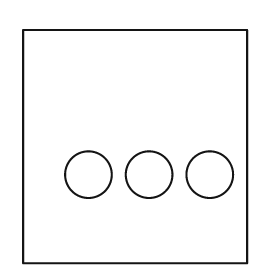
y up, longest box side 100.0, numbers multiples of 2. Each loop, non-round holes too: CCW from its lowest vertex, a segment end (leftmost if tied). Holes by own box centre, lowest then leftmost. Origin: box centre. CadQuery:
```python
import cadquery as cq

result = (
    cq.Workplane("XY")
    .moveTo(-48.0, -50.0)
    .lineTo(48.0, -50.0)
    .lineTo(48.0, 50.0)
    .lineTo(-48.0, 50.0)
    .close()
    .moveTo(-20.0, -12.0)
    .circle(10.0)
    .moveTo(6.0, -12.0)
    .circle(10.0)
    .moveTo(32.0, -12.0)
    .circle(10.0)
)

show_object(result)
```